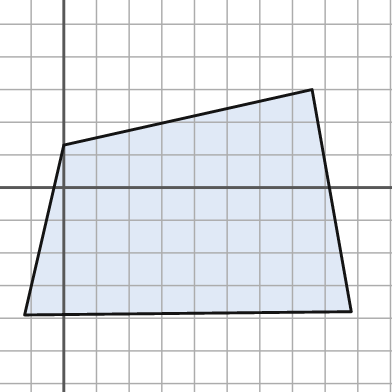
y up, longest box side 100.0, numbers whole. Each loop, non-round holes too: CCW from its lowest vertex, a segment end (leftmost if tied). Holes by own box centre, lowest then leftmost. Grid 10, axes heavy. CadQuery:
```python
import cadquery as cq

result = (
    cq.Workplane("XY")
    .moveTo(-12.0, -39.0)
    .lineTo(88.0, -38.0)
    .lineTo(76.0, 30.0)
    .lineTo(0.0, 13.0)
    .close()
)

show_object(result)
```